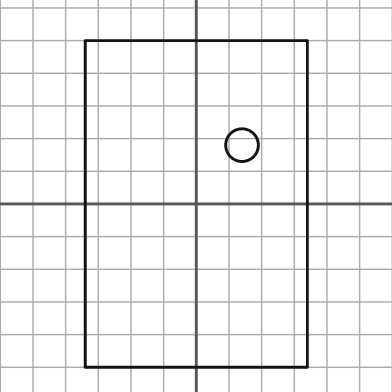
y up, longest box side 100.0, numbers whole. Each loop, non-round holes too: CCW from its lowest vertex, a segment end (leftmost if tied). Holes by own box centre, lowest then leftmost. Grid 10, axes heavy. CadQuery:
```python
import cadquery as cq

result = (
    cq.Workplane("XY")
    .moveTo(-34.0, -50.0)
    .lineTo(34.0, -50.0)
    .lineTo(34.0, 50.0)
    .lineTo(-34.0, 50.0)
    .close()
    .moveTo(14.0, 18.0)
    .circle(5.0)
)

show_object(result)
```